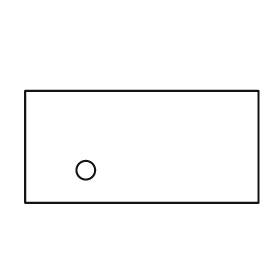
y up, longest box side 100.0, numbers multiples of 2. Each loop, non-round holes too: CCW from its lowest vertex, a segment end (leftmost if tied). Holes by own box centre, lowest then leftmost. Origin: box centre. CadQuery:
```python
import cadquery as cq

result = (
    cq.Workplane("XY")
    .moveTo(-50.0, -24.0)
    .lineTo(50.0, -24.0)
    .lineTo(50.0, 24.0)
    .lineTo(-50.0, 24.0)
    .close()
    .moveTo(-24.0, -10.0)
    .circle(4.0)
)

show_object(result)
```